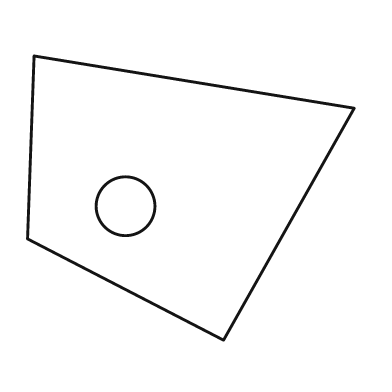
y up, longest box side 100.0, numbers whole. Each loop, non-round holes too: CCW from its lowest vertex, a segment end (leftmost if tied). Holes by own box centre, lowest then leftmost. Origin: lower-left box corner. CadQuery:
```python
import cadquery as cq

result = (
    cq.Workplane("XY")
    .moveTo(60.0, 0.0)
    .lineTo(100.0, 71.0)
    .lineTo(2.0, 87.0)
    .lineTo(0.0, 31.0)
    .close()
    .moveTo(30.0, 41.0)
    .circle(9.0)
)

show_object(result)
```